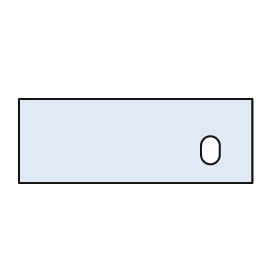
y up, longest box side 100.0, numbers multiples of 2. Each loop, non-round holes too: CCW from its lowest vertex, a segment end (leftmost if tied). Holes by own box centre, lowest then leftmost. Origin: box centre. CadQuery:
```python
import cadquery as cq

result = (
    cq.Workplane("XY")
    .moveTo(-50.0, -18.0)
    .lineTo(50.0, -18.0)
    .lineTo(50.0, 18.0)
    .lineTo(-50.0, 18.0)
    .close()
    .moveTo(28.0, -6.0)
    .threePointArc((32.0, -10.0), (36.0, -6.0))
    .lineTo(36.0, -2.0)
    .threePointArc((32.0, 2.0), (28.0, -2.0))
    .close()
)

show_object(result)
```